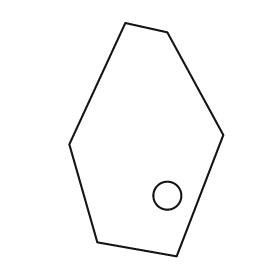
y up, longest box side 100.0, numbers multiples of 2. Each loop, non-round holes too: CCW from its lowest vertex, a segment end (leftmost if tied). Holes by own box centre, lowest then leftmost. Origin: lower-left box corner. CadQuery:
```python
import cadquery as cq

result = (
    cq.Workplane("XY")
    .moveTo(46.0, 0.0)
    .lineTo(66.0, 52.0)
    .lineTo(42.0, 96.0)
    .lineTo(24.0, 100.0)
    .lineTo(0.0, 48.0)
    .lineTo(12.0, 6.0)
    .close()
    .moveTo(42.0, 26.0)
    .circle(6.0)
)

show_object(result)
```